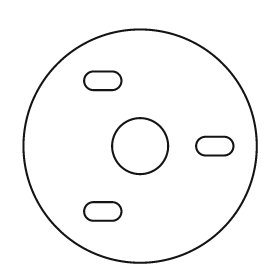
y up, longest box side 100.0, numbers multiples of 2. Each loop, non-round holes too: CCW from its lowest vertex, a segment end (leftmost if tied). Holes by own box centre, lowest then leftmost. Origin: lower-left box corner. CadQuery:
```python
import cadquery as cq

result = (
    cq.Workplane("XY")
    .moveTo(50.0, 50.0)
    .circle(50.0)
    .moveTo(30.0, 18.0)
    .lineTo(38.0, 18.0)
    .threePointArc((42.0, 22.0), (38.0, 26.0))
    .lineTo(30.0, 26.0)
    .threePointArc((26.0, 22.0), (30.0, 18.0))
    .close()
    .moveTo(50.0, 50.0)
    .circle(12.0)
    .moveTo(78.0, 46.0)
    .lineTo(86.0, 46.0)
    .threePointArc((90.0, 50.0), (86.0, 54.0))
    .lineTo(78.0, 54.0)
    .threePointArc((74.0, 50.0), (78.0, 46.0))
    .close()
    .moveTo(30.0, 74.0)
    .lineTo(38.0, 74.0)
    .threePointArc((42.0, 78.0), (38.0, 82.0))
    .lineTo(30.0, 82.0)
    .threePointArc((26.0, 78.0), (30.0, 74.0))
    .close()
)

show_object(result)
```